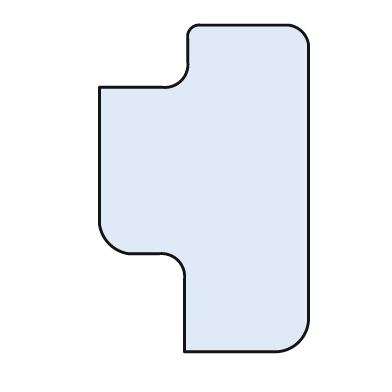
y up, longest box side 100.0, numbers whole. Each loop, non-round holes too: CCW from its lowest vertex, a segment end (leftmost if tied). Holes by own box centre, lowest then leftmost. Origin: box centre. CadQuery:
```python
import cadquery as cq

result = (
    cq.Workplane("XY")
    .moveTo(-6.0, -50.0)
    .lineTo(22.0, -50.0)
    .threePointArc((29.0, -47.0), (32.0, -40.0))
    .lineTo(32.0, 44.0)
    .threePointArc((30.0, 48.0), (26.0, 50.0))
    .lineTo(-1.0, 50.0)
    .threePointArc((-4.0, 49.0), (-5.0, 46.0))
    .lineTo(-5.0, 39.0)
    .threePointArc((-7.0, 33.0), (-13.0, 31.0))
    .lineTo(-32.0, 31.0)
    .lineTo(-32.0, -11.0)
    .threePointArc((-29.0, -17.0), (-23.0, -20.0))
    .lineTo(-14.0, -20.0)
    .threePointArc((-8.0, -22.0), (-6.0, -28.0))
    .close()
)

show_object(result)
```